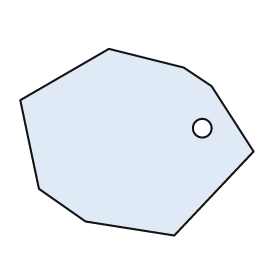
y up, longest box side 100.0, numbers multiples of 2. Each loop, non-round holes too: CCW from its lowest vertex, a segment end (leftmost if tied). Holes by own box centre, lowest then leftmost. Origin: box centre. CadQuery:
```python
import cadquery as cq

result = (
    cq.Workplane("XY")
    .moveTo(16.0, -40.0)
    .lineTo(50.0, -4.0)
    .lineTo(32.0, 24.0)
    .lineTo(20.0, 32.0)
    .lineTo(-12.0, 40.0)
    .lineTo(-50.0, 18.0)
    .lineTo(-42.0, -20.0)
    .lineTo(-22.0, -34.0)
    .close()
    .moveTo(28.0, 6.0)
    .circle(4.0)
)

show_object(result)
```